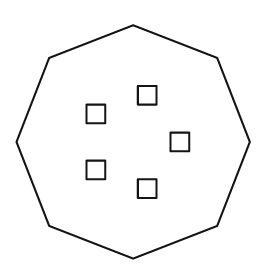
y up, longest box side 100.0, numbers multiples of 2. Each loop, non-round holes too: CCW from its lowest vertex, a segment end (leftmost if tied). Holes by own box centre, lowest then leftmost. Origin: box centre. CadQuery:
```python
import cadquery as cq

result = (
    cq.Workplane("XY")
    .moveTo(0.0, -50.0)
    .lineTo(36.0, -36.0)
    .lineTo(50.0, 0.0)
    .lineTo(36.0, 36.0)
    .lineTo(0.0, 50.0)
    .lineTo(-36.0, 36.0)
    .lineTo(-50.0, 0.0)
    .lineTo(-36.0, -36.0)
    .close()
    .moveTo(2.0, -24.0)
    .lineTo(10.0, -24.0)
    .lineTo(10.0, -16.0)
    .lineTo(2.0, -16.0)
    .close()
    .moveTo(-20.0, -16.0)
    .lineTo(-12.0, -16.0)
    .lineTo(-12.0, -8.0)
    .lineTo(-20.0, -8.0)
    .close()
    .moveTo(16.0, -4.0)
    .lineTo(24.0, -4.0)
    .lineTo(24.0, 4.0)
    .lineTo(16.0, 4.0)
    .close()
    .moveTo(-20.0, 8.0)
    .lineTo(-12.0, 8.0)
    .lineTo(-12.0, 16.0)
    .lineTo(-20.0, 16.0)
    .close()
    .moveTo(2.0, 16.0)
    .lineTo(10.0, 16.0)
    .lineTo(10.0, 24.0)
    .lineTo(2.0, 24.0)
    .close()
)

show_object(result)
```